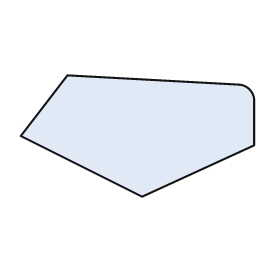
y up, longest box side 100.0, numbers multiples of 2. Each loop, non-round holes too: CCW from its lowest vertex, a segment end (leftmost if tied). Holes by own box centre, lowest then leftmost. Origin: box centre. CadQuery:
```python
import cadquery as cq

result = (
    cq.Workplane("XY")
    .moveTo(2.0, -26.0)
    .lineTo(50.0, -4.0)
    .lineTo(50.0, 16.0)
    .threePointArc((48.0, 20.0), (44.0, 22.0))
    .lineTo(-30.0, 26.0)
    .lineTo(-50.0, 0.0)
    .close()
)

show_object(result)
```